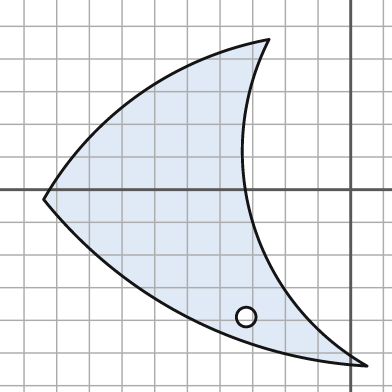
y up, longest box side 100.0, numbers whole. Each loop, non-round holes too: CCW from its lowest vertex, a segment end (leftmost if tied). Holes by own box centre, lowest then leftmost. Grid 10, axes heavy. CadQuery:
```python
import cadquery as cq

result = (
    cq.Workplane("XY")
    .moveTo(5.0, -54.0)
    .threePointArc((-30.0, -10.0), (-25.0, 46.0))
    .threePointArc((-65.0, 29.0), (-94.0, -3.0))
    .threePointArc((-50.0, -39.0), (5.0, -54.0))
    .close()
    .moveTo(-32.0, -39.0)
    .circle(3.0)
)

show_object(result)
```